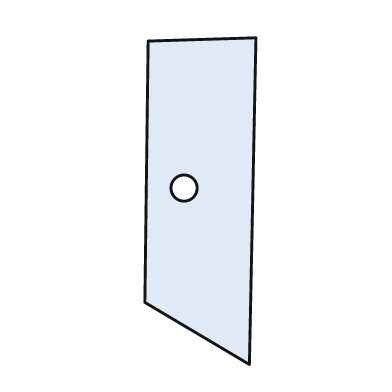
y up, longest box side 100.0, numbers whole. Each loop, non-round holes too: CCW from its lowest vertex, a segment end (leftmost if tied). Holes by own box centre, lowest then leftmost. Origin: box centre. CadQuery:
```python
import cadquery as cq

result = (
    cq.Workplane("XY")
    .moveTo(15.0, -50.0)
    .lineTo(17.0, 50.0)
    .lineTo(-16.0, 49.0)
    .lineTo(-17.0, -31.0)
    .close()
    .moveTo(-5.0, 4.0)
    .circle(4.0)
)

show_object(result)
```